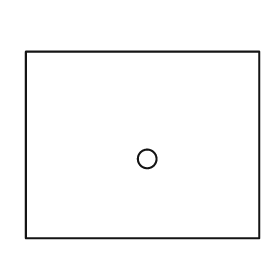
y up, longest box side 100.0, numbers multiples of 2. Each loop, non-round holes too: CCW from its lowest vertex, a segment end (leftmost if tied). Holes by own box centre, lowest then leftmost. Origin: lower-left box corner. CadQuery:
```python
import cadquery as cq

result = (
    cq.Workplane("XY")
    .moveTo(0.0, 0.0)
    .lineTo(100.0, 0.0)
    .lineTo(100.0, 80.0)
    .lineTo(0.0, 80.0)
    .close()
    .moveTo(52.0, 34.0)
    .circle(4.0)
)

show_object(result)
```